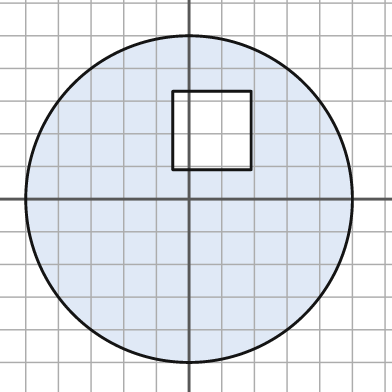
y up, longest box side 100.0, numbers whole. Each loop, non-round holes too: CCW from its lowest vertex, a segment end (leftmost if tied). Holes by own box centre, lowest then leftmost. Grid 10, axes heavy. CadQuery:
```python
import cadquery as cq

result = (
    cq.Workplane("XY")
    .moveTo(0.0, 0.0)
    .circle(50.0)
    .moveTo(-5.0, 9.0)
    .lineTo(19.0, 9.0)
    .lineTo(19.0, 33.0)
    .lineTo(-5.0, 33.0)
    .close()
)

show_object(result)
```